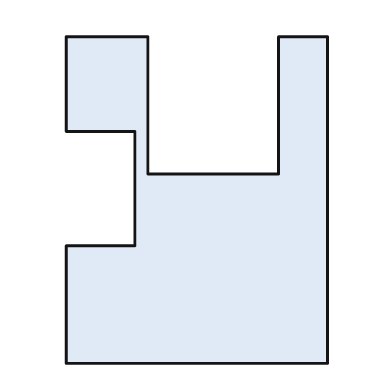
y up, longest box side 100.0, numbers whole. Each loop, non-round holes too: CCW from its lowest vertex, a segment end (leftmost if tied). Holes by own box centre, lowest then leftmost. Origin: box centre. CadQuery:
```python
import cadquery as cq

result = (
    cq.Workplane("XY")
    .moveTo(-40.0, -50.0)
    .lineTo(40.0, -50.0)
    .lineTo(40.0, 50.0)
    .lineTo(25.0, 50.0)
    .lineTo(25.0, 8.0)
    .lineTo(-15.0, 8.0)
    .lineTo(-15.0, 50.0)
    .lineTo(-40.0, 50.0)
    .lineTo(-40.0, 21.0)
    .lineTo(-19.0, 21.0)
    .lineTo(-19.0, -14.0)
    .lineTo(-40.0, -14.0)
    .close()
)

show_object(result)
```